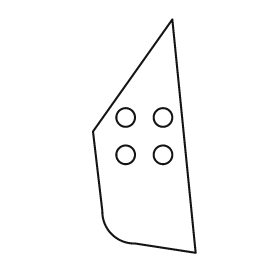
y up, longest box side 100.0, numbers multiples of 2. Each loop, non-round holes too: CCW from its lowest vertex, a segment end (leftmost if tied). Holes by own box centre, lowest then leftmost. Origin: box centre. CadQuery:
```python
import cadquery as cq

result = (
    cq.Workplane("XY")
    .moveTo(22.0, -50.0)
    .lineTo(12.0, 50.0)
    .lineTo(-22.0, 2.0)
    .lineTo(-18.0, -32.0)
    .threePointArc((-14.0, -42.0), (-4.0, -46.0))
    .close()
    .moveTo(-8.0, -8.0)
    .circle(4.0)
    .moveTo(8.0, -8.0)
    .circle(4.0)
    .moveTo(-8.0, 8.0)
    .circle(4.0)
    .moveTo(8.0, 8.0)
    .circle(4.0)
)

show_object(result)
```